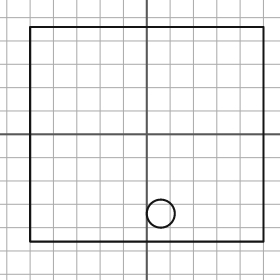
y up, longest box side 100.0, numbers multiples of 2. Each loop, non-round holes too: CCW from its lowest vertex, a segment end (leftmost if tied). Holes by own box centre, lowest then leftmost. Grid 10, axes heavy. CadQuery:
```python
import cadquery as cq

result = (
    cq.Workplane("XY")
    .moveTo(-50.0, -46.0)
    .lineTo(50.0, -46.0)
    .lineTo(50.0, 46.0)
    .lineTo(-50.0, 46.0)
    .close()
    .moveTo(6.0, -34.0)
    .circle(6.0)
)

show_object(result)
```